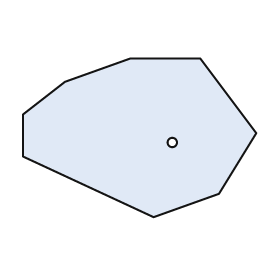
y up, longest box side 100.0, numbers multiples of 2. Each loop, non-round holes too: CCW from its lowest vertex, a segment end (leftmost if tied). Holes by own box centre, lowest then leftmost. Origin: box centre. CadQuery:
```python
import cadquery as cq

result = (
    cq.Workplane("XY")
    .moveTo(6.0, -34.0)
    .lineTo(34.0, -24.0)
    .lineTo(50.0, 2.0)
    .lineTo(26.0, 34.0)
    .lineTo(-4.0, 34.0)
    .lineTo(-32.0, 24.0)
    .lineTo(-50.0, 10.0)
    .lineTo(-50.0, -8.0)
    .close()
    .moveTo(14.0, -2.0)
    .circle(2.0)
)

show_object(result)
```